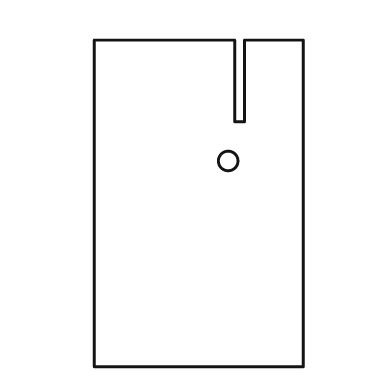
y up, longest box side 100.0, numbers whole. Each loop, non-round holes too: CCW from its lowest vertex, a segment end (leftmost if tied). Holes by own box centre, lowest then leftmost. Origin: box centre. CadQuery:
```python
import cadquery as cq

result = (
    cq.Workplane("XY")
    .moveTo(-32.0, -50.0)
    .lineTo(32.0, -50.0)
    .lineTo(32.0, 50.0)
    .lineTo(14.0, 50.0)
    .lineTo(14.0, 25.0)
    .lineTo(11.0, 25.0)
    .lineTo(11.0, 50.0)
    .lineTo(-32.0, 50.0)
    .close()
    .moveTo(9.0, 13.0)
    .circle(3.0)
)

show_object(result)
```